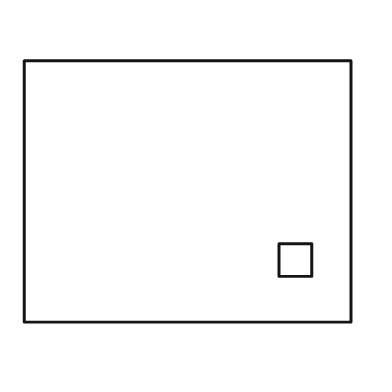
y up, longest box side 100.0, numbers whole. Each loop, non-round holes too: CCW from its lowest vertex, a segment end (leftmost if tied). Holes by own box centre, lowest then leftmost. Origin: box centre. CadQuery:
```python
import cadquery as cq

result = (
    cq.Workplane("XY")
    .moveTo(-50.0, -40.0)
    .lineTo(50.0, -40.0)
    .lineTo(50.0, 40.0)
    .lineTo(-50.0, 40.0)
    .close()
    .moveTo(28.0, -26.0)
    .lineTo(38.0, -26.0)
    .lineTo(38.0, -16.0)
    .lineTo(28.0, -16.0)
    .close()
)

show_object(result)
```